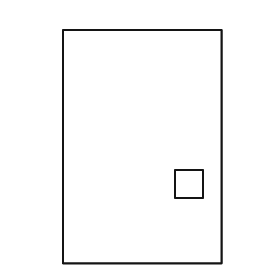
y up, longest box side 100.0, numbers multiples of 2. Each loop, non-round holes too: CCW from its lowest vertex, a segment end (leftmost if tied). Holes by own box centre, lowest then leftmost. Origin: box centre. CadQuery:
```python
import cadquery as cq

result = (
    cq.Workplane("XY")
    .moveTo(-34.0, -50.0)
    .lineTo(34.0, -50.0)
    .lineTo(34.0, 50.0)
    .lineTo(-34.0, 50.0)
    .close()
    .moveTo(14.0, -22.0)
    .lineTo(26.0, -22.0)
    .lineTo(26.0, -10.0)
    .lineTo(14.0, -10.0)
    .close()
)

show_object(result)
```